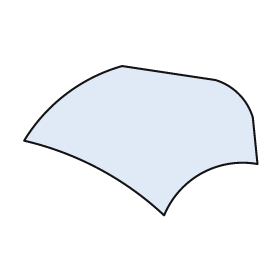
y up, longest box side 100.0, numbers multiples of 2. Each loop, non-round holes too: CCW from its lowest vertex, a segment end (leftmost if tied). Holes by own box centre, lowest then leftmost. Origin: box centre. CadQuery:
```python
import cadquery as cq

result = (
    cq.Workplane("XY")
    .moveTo(10.0, -32.0)
    .threePointArc((26.0, -14.0), (50.0, -10.0))
    .lineTo(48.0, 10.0)
    .threePointArc((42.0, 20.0), (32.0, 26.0))
    .lineTo(-8.0, 32.0)
    .threePointArc((-32.0, 20.0), (-50.0, 0.0))
    .threePointArc((-18.0, -12.0), (10.0, -32.0))
    .close()
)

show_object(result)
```